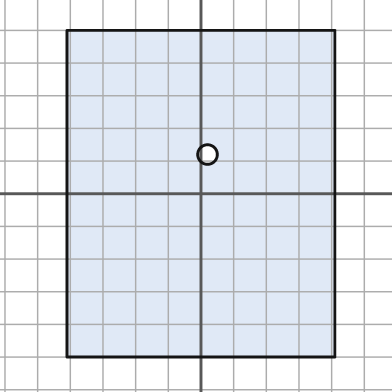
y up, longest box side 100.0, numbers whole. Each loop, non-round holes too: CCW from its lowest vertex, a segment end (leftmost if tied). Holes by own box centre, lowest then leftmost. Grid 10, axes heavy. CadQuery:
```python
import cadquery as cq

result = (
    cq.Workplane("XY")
    .moveTo(-41.0, -50.0)
    .lineTo(41.0, -50.0)
    .lineTo(41.0, 50.0)
    .lineTo(-41.0, 50.0)
    .close()
    .moveTo(2.0, 12.0)
    .circle(3.0)
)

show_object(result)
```